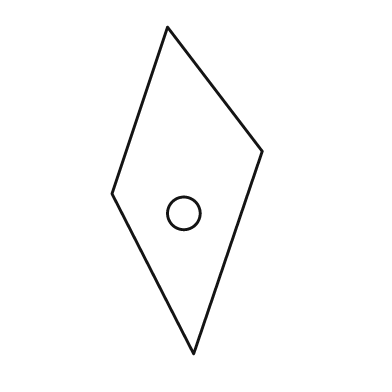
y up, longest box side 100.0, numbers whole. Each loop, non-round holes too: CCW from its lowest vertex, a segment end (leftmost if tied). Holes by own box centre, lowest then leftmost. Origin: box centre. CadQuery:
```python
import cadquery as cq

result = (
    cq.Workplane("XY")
    .moveTo(2.0, -50.0)
    .lineTo(23.0, 12.0)
    .lineTo(-6.0, 50.0)
    .lineTo(-23.0, -1.0)
    .close()
    .moveTo(-1.0, -7.0)
    .circle(5.0)
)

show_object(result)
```